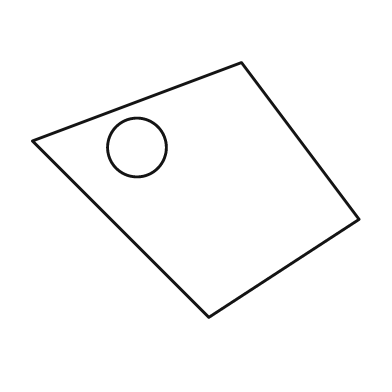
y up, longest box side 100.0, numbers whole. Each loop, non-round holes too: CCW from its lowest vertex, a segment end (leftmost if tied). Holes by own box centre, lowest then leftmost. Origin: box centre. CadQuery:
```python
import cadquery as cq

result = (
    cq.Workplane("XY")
    .moveTo(4.0, -39.0)
    .lineTo(50.0, -9.0)
    .lineTo(14.0, 39.0)
    .lineTo(-50.0, 15.0)
    .close()
    .moveTo(-18.0, 13.0)
    .circle(9.0)
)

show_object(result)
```